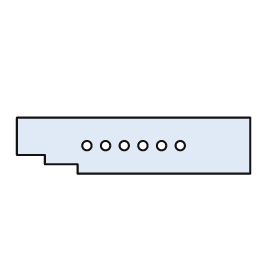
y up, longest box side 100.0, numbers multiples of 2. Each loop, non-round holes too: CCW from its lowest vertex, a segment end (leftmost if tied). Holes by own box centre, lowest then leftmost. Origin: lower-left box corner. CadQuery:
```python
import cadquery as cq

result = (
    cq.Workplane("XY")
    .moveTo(26.0, 0.0)
    .lineTo(100.0, 0.0)
    .lineTo(100.0, 24.0)
    .lineTo(0.0, 24.0)
    .lineTo(0.0, 8.0)
    .lineTo(12.0, 8.0)
    .lineTo(12.0, 4.0)
    .lineTo(26.0, 4.0)
    .close()
    .moveTo(30.0, 12.0)
    .circle(2.0)
    .moveTo(38.0, 12.0)
    .circle(2.0)
    .moveTo(46.0, 12.0)
    .circle(2.0)
    .moveTo(54.0, 12.0)
    .circle(2.0)
    .moveTo(62.0, 12.0)
    .circle(2.0)
    .moveTo(70.0, 12.0)
    .circle(2.0)
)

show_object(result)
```